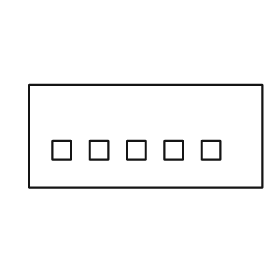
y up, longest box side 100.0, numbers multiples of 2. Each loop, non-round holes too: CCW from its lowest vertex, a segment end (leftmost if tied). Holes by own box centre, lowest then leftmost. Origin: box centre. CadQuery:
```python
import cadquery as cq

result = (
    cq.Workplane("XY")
    .moveTo(-50.0, -22.0)
    .lineTo(50.0, -22.0)
    .lineTo(50.0, 22.0)
    .lineTo(-50.0, 22.0)
    .close()
    .moveTo(-40.0, -10.0)
    .lineTo(-32.0, -10.0)
    .lineTo(-32.0, -2.0)
    .lineTo(-40.0, -2.0)
    .close()
    .moveTo(-24.0, -10.0)
    .lineTo(-16.0, -10.0)
    .lineTo(-16.0, -2.0)
    .lineTo(-24.0, -2.0)
    .close()
    .moveTo(-8.0, -10.0)
    .lineTo(0.0, -10.0)
    .lineTo(0.0, -2.0)
    .lineTo(-8.0, -2.0)
    .close()
    .moveTo(8.0, -10.0)
    .lineTo(16.0, -10.0)
    .lineTo(16.0, -2.0)
    .lineTo(8.0, -2.0)
    .close()
    .moveTo(24.0, -10.0)
    .lineTo(32.0, -10.0)
    .lineTo(32.0, -2.0)
    .lineTo(24.0, -2.0)
    .close()
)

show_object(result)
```